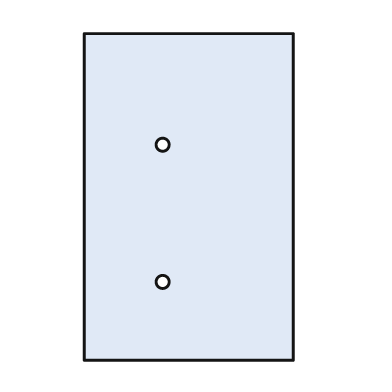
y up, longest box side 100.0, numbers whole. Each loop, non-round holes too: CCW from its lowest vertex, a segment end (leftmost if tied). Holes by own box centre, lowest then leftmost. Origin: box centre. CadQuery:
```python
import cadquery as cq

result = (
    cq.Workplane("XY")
    .moveTo(-32.0, -50.0)
    .lineTo(32.0, -50.0)
    .lineTo(32.0, 50.0)
    .lineTo(-32.0, 50.0)
    .close()
    .moveTo(-8.0, -26.0)
    .circle(2.0)
    .moveTo(-8.0, 16.0)
    .circle(2.0)
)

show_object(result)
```